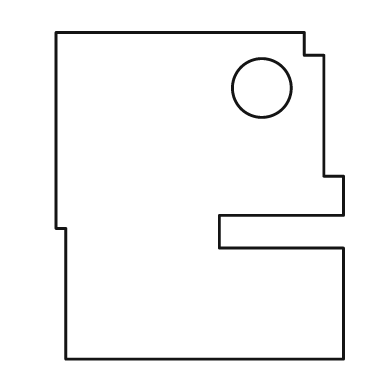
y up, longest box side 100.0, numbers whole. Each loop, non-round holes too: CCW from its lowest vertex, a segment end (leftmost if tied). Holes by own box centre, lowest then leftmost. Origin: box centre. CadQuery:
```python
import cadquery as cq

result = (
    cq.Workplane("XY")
    .moveTo(-41.0, -50.0)
    .lineTo(44.0, -50.0)
    .lineTo(44.0, -16.0)
    .lineTo(6.0, -16.0)
    .lineTo(6.0, -6.0)
    .lineTo(44.0, -6.0)
    .lineTo(44.0, 6.0)
    .lineTo(38.0, 6.0)
    .lineTo(38.0, 43.0)
    .lineTo(32.0, 43.0)
    .lineTo(32.0, 50.0)
    .lineTo(-44.0, 50.0)
    .lineTo(-44.0, -10.0)
    .lineTo(-41.0, -10.0)
    .close()
    .moveTo(19.0, 33.0)
    .circle(9.0)
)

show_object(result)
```